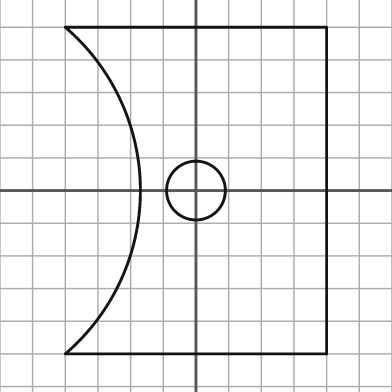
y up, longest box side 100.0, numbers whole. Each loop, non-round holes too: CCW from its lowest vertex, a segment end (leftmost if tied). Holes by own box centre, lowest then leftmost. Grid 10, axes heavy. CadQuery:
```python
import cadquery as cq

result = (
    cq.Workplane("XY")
    .moveTo(-40.0, -50.0)
    .lineTo(40.0, -50.0)
    .lineTo(40.0, 50.0)
    .lineTo(-40.0, 50.0)
    .threePointArc((-17.0, 0.0), (-40.0, -50.0))
    .close()
    .moveTo(0.0, 0.0)
    .circle(9.0)
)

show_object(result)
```